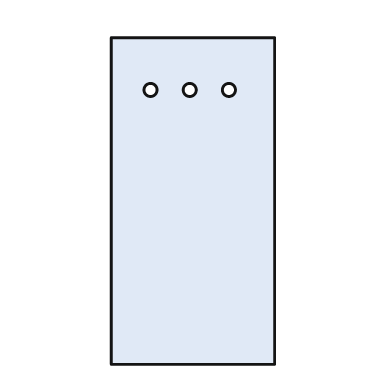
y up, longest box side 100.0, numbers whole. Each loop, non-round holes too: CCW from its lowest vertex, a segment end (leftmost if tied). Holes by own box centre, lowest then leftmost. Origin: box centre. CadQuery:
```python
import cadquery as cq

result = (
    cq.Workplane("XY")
    .moveTo(-25.0, -50.0)
    .lineTo(25.0, -50.0)
    .lineTo(25.0, 50.0)
    .lineTo(-25.0, 50.0)
    .close()
    .moveTo(-13.0, 34.0)
    .circle(2.0)
    .moveTo(-1.0, 34.0)
    .circle(2.0)
    .moveTo(11.0, 34.0)
    .circle(2.0)
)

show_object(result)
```